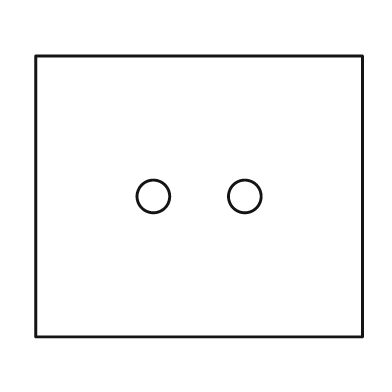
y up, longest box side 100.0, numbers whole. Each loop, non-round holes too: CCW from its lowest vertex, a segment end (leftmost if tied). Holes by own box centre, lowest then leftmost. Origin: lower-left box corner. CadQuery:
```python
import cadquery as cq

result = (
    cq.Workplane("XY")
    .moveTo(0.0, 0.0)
    .lineTo(100.0, 0.0)
    .lineTo(100.0, 86.0)
    .lineTo(0.0, 86.0)
    .close()
    .moveTo(36.0, 43.0)
    .circle(5.0)
    .moveTo(64.0, 43.0)
    .circle(5.0)
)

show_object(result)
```